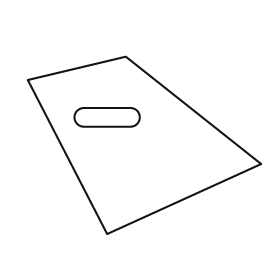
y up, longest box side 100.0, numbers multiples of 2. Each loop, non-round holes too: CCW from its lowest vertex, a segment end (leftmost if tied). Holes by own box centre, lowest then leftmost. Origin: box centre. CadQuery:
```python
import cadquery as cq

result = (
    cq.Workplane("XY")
    .moveTo(-16.0, -38.0)
    .lineTo(50.0, -8.0)
    .lineTo(-8.0, 38.0)
    .lineTo(-50.0, 28.0)
    .close()
    .moveTo(-26.0, 8.0)
    .lineTo(-6.0, 8.0)
    .threePointArc((-2.0, 12.0), (-6.0, 16.0))
    .lineTo(-26.0, 16.0)
    .threePointArc((-30.0, 12.0), (-26.0, 8.0))
    .close()
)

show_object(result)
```